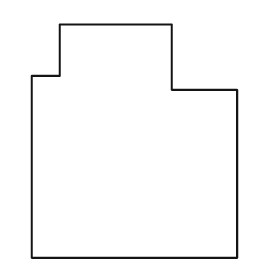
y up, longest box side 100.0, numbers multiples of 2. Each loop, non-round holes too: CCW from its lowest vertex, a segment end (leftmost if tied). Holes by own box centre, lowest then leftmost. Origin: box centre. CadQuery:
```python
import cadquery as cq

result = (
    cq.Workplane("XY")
    .moveTo(-44.0, -50.0)
    .lineTo(44.0, -50.0)
    .lineTo(44.0, 22.0)
    .lineTo(16.0, 22.0)
    .lineTo(16.0, 50.0)
    .lineTo(-32.0, 50.0)
    .lineTo(-32.0, 28.0)
    .lineTo(-44.0, 28.0)
    .close()
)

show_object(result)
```